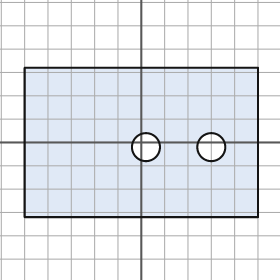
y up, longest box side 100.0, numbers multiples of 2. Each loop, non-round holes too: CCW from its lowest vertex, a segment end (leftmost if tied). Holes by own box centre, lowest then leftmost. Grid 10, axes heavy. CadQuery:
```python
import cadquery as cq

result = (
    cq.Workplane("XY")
    .moveTo(-50.0, -32.0)
    .lineTo(50.0, -32.0)
    .lineTo(50.0, 32.0)
    .lineTo(-50.0, 32.0)
    .close()
    .moveTo(2.0, -2.0)
    .circle(6.0)
    .moveTo(30.0, -2.0)
    .circle(6.0)
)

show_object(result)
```